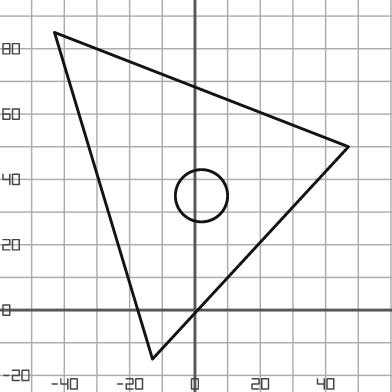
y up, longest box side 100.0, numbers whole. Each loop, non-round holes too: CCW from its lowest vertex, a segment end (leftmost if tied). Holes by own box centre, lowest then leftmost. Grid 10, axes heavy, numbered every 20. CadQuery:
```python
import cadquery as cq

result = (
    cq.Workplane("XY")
    .moveTo(-13.0, -15.0)
    .lineTo(47.0, 50.0)
    .lineTo(-43.0, 85.0)
    .close()
    .moveTo(2.0, 35.0)
    .circle(8.0)
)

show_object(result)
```